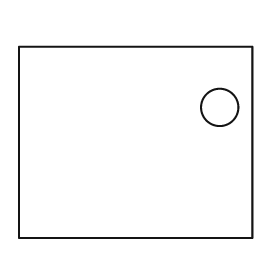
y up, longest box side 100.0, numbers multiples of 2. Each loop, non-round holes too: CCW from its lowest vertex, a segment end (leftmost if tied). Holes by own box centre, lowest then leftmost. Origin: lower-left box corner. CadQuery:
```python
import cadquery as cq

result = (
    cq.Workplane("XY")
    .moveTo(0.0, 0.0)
    .lineTo(100.0, 0.0)
    .lineTo(100.0, 82.0)
    .lineTo(0.0, 82.0)
    .close()
    .moveTo(86.0, 56.0)
    .circle(8.0)
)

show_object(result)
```